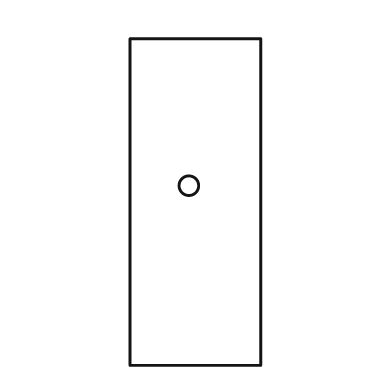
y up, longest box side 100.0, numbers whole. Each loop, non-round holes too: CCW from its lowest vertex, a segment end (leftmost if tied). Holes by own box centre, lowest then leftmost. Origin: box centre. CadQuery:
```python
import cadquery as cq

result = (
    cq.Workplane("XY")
    .moveTo(-20.0, -50.0)
    .lineTo(20.0, -50.0)
    .lineTo(20.0, 50.0)
    .lineTo(-20.0, 50.0)
    .close()
    .moveTo(-2.0, 5.0)
    .circle(3.0)
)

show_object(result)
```